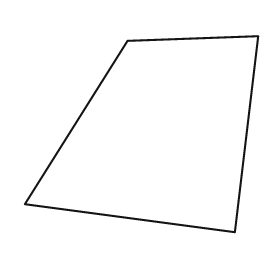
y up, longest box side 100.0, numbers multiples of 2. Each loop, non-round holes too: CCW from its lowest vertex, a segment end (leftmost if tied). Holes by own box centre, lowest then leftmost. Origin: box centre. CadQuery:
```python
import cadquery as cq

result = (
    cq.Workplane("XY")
    .moveTo(40.0, -42.0)
    .lineTo(50.0, 42.0)
    .lineTo(-6.0, 40.0)
    .lineTo(-50.0, -30.0)
    .close()
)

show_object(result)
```